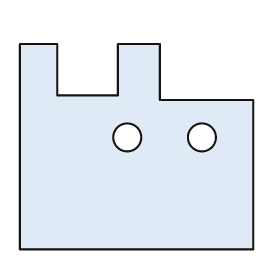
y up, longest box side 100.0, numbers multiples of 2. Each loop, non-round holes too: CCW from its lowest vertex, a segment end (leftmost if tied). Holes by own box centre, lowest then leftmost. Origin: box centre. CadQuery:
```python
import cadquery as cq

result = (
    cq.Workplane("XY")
    .moveTo(-50.0, -44.0)
    .lineTo(50.0, -44.0)
    .lineTo(50.0, 20.0)
    .lineTo(10.0, 20.0)
    .lineTo(10.0, 44.0)
    .lineTo(-8.0, 44.0)
    .lineTo(-8.0, 22.0)
    .lineTo(-34.0, 22.0)
    .lineTo(-34.0, 44.0)
    .lineTo(-50.0, 44.0)
    .close()
    .moveTo(-4.0, 4.0)
    .circle(6.0)
    .moveTo(28.0, 4.0)
    .circle(6.0)
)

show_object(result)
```